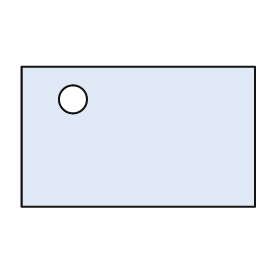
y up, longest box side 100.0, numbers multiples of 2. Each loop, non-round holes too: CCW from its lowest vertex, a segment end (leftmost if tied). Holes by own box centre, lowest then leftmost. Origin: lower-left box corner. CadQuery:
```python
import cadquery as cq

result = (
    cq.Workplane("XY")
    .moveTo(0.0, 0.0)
    .lineTo(100.0, 0.0)
    .lineTo(100.0, 60.0)
    .lineTo(0.0, 60.0)
    .close()
    .moveTo(22.0, 46.0)
    .circle(6.0)
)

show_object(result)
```